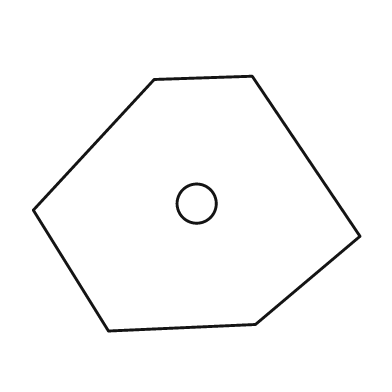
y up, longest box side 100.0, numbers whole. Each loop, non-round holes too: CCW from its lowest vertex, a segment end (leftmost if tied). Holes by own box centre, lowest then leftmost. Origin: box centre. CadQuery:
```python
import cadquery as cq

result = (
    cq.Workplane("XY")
    .moveTo(-27.0, -39.0)
    .lineTo(18.0, -37.0)
    .lineTo(50.0, -10.0)
    .lineTo(17.0, 39.0)
    .lineTo(-13.0, 38.0)
    .lineTo(-50.0, -2.0)
    .close()
    .moveTo(0.0, 0.0)
    .circle(6.0)
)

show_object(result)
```